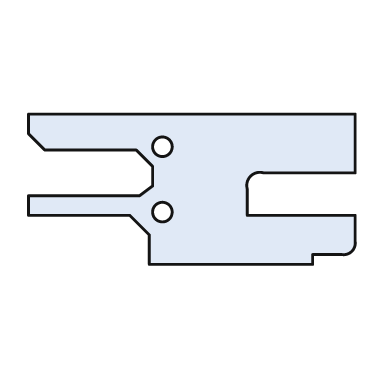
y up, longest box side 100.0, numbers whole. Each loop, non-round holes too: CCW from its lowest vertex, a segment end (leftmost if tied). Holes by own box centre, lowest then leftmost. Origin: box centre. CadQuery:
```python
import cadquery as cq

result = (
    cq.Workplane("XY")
    .moveTo(-13.0, -23.0)
    .lineTo(37.0, -23.0)
    .lineTo(37.0, -20.0)
    .lineTo(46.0, -20.0)
    .threePointArc((49.0, -19.0), (50.0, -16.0))
    .lineTo(50.0, -8.0)
    .lineTo(17.0, -8.0)
    .lineTo(17.0, 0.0)
    .threePointArc((18.0, 4.0), (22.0, 5.0))
    .lineTo(50.0, 5.0)
    .lineTo(50.0, 23.0)
    .lineTo(-50.0, 23.0)
    .lineTo(-50.0, 17.0)
    .lineTo(-45.0, 12.0)
    .lineTo(-17.0, 12.0)
    .lineTo(-12.0, 7.0)
    .lineTo(-12.0, 1.0)
    .lineTo(-16.0, -2.0)
    .lineTo(-50.0, -2.0)
    .lineTo(-50.0, -8.0)
    .lineTo(-19.0, -8.0)
    .lineTo(-13.0, -14.0)
    .close()
    .moveTo(-9.0, -7.0)
    .circle(3.0)
    .moveTo(-9.0, 13.0)
    .circle(3.0)
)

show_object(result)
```